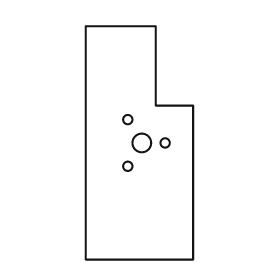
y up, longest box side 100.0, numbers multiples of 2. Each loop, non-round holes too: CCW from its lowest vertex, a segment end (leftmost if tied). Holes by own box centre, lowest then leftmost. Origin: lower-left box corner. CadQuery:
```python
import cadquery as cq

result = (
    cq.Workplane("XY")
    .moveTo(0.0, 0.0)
    .lineTo(46.0, 0.0)
    .lineTo(46.0, 66.0)
    .lineTo(30.0, 66.0)
    .lineTo(30.0, 100.0)
    .lineTo(0.0, 100.0)
    .close()
    .moveTo(18.0, 40.0)
    .circle(2.0)
    .moveTo(24.0, 50.0)
    .circle(4.0)
    .moveTo(34.0, 50.0)
    .circle(2.0)
    .moveTo(18.0, 60.0)
    .circle(2.0)
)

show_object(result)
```